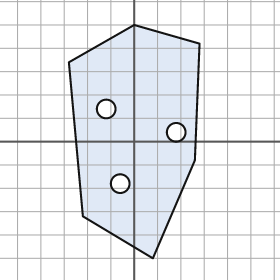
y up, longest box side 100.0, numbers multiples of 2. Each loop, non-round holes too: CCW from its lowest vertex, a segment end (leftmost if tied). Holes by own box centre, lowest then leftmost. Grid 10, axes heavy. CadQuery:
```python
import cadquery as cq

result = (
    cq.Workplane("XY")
    .moveTo(8.0, -50.0)
    .lineTo(26.0, -8.0)
    .lineTo(28.0, 42.0)
    .lineTo(0.0, 50.0)
    .lineTo(-28.0, 34.0)
    .lineTo(-22.0, -32.0)
    .close()
    .moveTo(-6.0, -18.0)
    .circle(4.0)
    .moveTo(18.0, 4.0)
    .circle(4.0)
    .moveTo(-12.0, 14.0)
    .circle(4.0)
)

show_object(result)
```